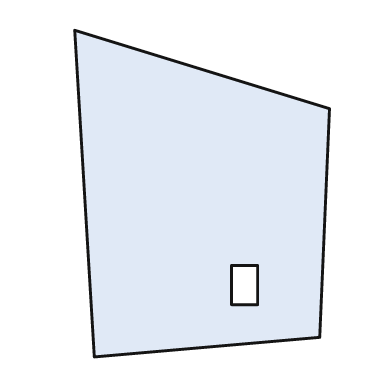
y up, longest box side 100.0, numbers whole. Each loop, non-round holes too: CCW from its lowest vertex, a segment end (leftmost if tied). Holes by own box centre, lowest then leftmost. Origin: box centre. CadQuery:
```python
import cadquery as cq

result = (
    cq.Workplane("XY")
    .moveTo(-33.0, -50.0)
    .lineTo(36.0, -44.0)
    .lineTo(39.0, 26.0)
    .lineTo(-39.0, 50.0)
    .close()
    .moveTo(9.0, -34.0)
    .lineTo(17.0, -34.0)
    .lineTo(17.0, -22.0)
    .lineTo(9.0, -22.0)
    .close()
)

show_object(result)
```